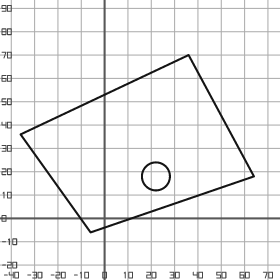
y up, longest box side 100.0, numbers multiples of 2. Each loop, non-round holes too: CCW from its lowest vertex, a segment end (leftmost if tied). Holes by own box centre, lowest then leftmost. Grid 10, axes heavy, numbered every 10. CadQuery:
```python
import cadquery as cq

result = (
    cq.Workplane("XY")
    .moveTo(-6.0, -6.0)
    .lineTo(64.0, 18.0)
    .lineTo(36.0, 70.0)
    .lineTo(-36.0, 36.0)
    .close()
    .moveTo(22.0, 18.0)
    .circle(6.0)
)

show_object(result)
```